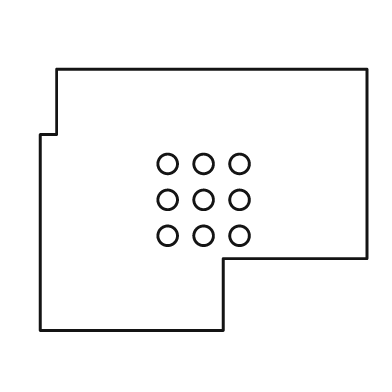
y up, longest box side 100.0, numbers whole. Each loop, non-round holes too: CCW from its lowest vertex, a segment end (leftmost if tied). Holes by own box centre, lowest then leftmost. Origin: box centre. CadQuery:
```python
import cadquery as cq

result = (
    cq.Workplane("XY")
    .moveTo(-50.0, -40.0)
    .lineTo(6.0, -40.0)
    .lineTo(6.0, -18.0)
    .lineTo(50.0, -18.0)
    .lineTo(50.0, 40.0)
    .lineTo(-45.0, 40.0)
    .lineTo(-45.0, 20.0)
    .lineTo(-50.0, 20.0)
    .close()
    .moveTo(-11.0, -11.0)
    .circle(3.0)
    .moveTo(0.0, -11.0)
    .circle(3.0)
    .moveTo(11.0, -11.0)
    .circle(3.0)
    .moveTo(-11.0, 0.0)
    .circle(3.0)
    .moveTo(0.0, 0.0)
    .circle(3.0)
    .moveTo(11.0, 0.0)
    .circle(3.0)
    .moveTo(-11.0, 11.0)
    .circle(3.0)
    .moveTo(0.0, 11.0)
    .circle(3.0)
    .moveTo(11.0, 11.0)
    .circle(3.0)
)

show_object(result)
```